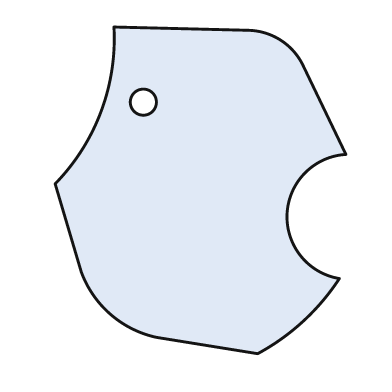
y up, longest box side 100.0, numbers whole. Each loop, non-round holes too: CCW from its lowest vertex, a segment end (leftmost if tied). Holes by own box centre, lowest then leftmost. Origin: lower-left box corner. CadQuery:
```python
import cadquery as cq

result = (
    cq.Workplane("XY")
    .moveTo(62.0, 0.0)
    .threePointArc((76.0, 10.0), (87.0, 23.0))
    .threePointArc((71.0, 43.0), (89.0, 61.0))
    .lineTo(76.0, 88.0)
    .threePointArc((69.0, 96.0), (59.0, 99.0))
    .lineTo(18.0, 100.0)
    .threePointArc((14.0, 74.0), (0.0, 52.0))
    .lineTo(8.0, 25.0)
    .threePointArc((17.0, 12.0), (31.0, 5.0))
    .close()
    .moveTo(27.0, 77.0)
    .circle(4.0)
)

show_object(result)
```